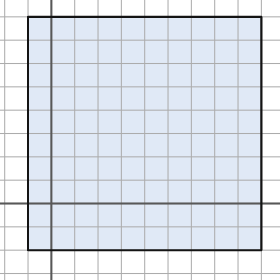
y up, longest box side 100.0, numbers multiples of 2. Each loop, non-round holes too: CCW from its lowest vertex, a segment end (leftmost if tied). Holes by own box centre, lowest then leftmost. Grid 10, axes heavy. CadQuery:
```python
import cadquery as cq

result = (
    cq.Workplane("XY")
    .moveTo(-10.0, -20.0)
    .lineTo(90.0, -20.0)
    .lineTo(90.0, 80.0)
    .lineTo(-10.0, 80.0)
    .close()
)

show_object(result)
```